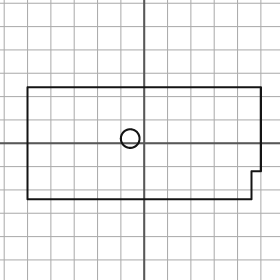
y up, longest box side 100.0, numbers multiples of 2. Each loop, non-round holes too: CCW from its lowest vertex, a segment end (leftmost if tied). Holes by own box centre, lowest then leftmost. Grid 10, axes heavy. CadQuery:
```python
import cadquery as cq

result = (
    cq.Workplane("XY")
    .moveTo(-50.0, -24.0)
    .lineTo(46.0, -24.0)
    .lineTo(46.0, -12.0)
    .lineTo(50.0, -12.0)
    .lineTo(50.0, 24.0)
    .lineTo(-50.0, 24.0)
    .close()
    .moveTo(-6.0, 2.0)
    .circle(4.0)
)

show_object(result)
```